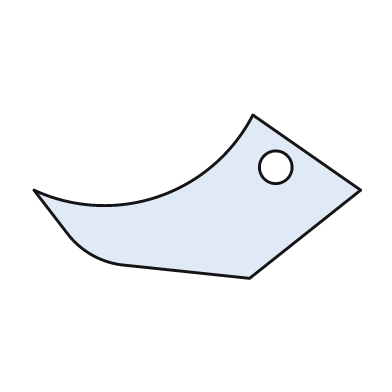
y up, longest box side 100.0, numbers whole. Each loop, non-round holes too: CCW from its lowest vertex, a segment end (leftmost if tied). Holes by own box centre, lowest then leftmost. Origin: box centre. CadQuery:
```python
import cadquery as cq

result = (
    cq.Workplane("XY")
    .moveTo(16.0, -25.0)
    .lineTo(50.0, 2.0)
    .lineTo(17.0, 25.0)
    .threePointArc((-12.0, 0.0), (-50.0, 2.0))
    .lineTo(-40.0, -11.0)
    .threePointArc((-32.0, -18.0), (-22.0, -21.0))
    .close()
    .moveTo(24.0, 9.0)
    .circle(5.0)
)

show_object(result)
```